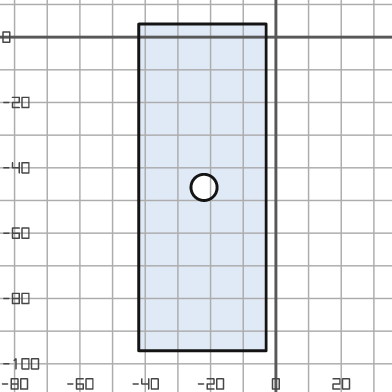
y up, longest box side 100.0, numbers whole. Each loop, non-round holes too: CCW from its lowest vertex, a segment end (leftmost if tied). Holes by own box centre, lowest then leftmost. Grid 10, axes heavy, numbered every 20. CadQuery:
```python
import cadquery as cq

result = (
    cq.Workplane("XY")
    .moveTo(-42.0, -96.0)
    .lineTo(-3.0, -96.0)
    .lineTo(-3.0, 4.0)
    .lineTo(-42.0, 4.0)
    .close()
    .moveTo(-22.0, -46.0)
    .circle(4.0)
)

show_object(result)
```